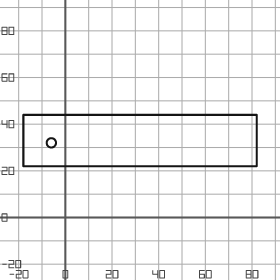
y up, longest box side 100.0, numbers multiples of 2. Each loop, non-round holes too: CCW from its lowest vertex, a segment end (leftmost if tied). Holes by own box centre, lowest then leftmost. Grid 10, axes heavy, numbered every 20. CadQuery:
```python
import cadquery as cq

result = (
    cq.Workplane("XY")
    .moveTo(-18.0, 22.0)
    .lineTo(82.0, 22.0)
    .lineTo(82.0, 44.0)
    .lineTo(-18.0, 44.0)
    .close()
    .moveTo(-6.0, 32.0)
    .circle(2.0)
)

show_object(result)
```